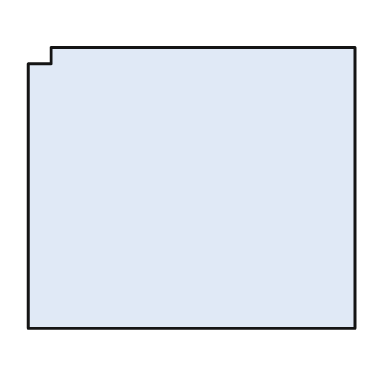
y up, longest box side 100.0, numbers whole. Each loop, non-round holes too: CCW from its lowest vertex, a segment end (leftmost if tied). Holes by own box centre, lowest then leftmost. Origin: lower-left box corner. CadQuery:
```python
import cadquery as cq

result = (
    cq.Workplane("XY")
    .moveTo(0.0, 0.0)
    .lineTo(100.0, 0.0)
    .lineTo(100.0, 86.0)
    .lineTo(7.0, 86.0)
    .lineTo(7.0, 81.0)
    .lineTo(0.0, 81.0)
    .close()
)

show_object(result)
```